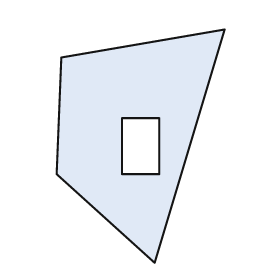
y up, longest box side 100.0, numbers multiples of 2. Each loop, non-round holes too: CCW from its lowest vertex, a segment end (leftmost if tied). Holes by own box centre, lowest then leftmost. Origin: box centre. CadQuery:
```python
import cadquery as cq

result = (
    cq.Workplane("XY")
    .moveTo(6.0, -50.0)
    .lineTo(36.0, 50.0)
    .lineTo(-34.0, 38.0)
    .lineTo(-36.0, -12.0)
    .close()
    .moveTo(-8.0, -12.0)
    .lineTo(8.0, -12.0)
    .lineTo(8.0, 12.0)
    .lineTo(-8.0, 12.0)
    .close()
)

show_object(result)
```